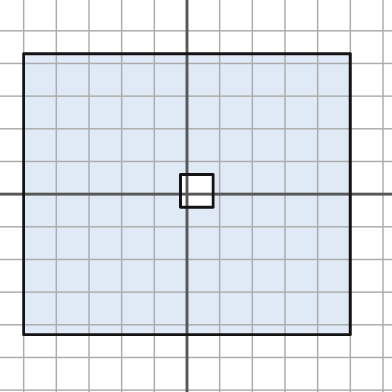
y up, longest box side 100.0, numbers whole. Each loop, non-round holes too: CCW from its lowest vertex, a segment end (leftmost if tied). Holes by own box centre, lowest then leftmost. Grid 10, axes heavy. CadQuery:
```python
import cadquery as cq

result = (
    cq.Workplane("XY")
    .moveTo(-50.0, -43.0)
    .lineTo(50.0, -43.0)
    .lineTo(50.0, 43.0)
    .lineTo(-50.0, 43.0)
    .close()
    .moveTo(-2.0, -4.0)
    .lineTo(8.0, -4.0)
    .lineTo(8.0, 6.0)
    .lineTo(-2.0, 6.0)
    .close()
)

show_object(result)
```